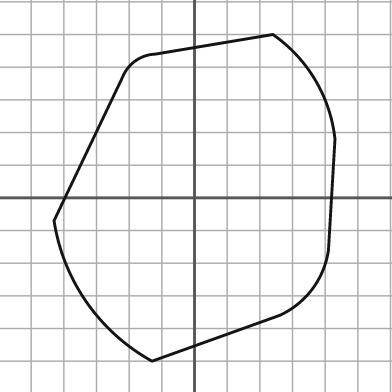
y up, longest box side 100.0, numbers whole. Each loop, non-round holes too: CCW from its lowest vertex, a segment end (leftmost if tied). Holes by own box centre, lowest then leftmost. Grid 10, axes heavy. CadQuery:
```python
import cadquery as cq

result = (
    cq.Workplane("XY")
    .moveTo(-13.0, -50.0)
    .lineTo(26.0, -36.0)
    .threePointArc((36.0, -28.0), (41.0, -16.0))
    .lineTo(43.0, 18.0)
    .threePointArc((37.0, 36.0), (24.0, 50.0))
    .lineTo(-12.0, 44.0)
    .threePointArc((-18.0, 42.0), (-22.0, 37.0))
    .lineTo(-43.0, -7.0)
    .threePointArc((-33.0, -32.0), (-13.0, -50.0))
    .close()
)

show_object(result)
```